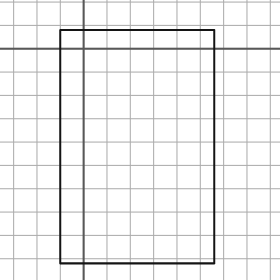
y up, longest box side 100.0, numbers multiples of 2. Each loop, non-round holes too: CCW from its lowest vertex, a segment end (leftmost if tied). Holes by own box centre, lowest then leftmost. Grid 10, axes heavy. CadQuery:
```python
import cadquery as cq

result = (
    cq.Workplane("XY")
    .moveTo(-10.0, -92.0)
    .lineTo(56.0, -92.0)
    .lineTo(56.0, 8.0)
    .lineTo(-10.0, 8.0)
    .close()
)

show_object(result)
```